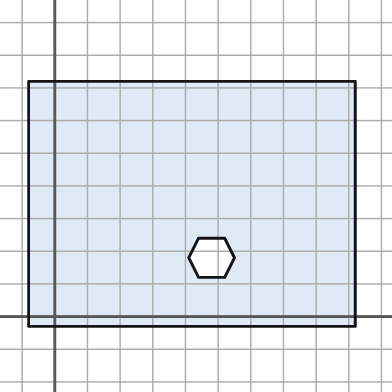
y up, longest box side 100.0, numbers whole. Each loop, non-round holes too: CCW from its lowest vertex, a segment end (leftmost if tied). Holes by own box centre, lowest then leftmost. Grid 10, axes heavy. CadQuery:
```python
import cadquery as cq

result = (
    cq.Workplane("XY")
    .moveTo(-8.0, -3.0)
    .lineTo(92.0, -3.0)
    .lineTo(92.0, 72.0)
    .lineTo(-8.0, 72.0)
    .close()
    .moveTo(44.0, 12.0)
    .lineTo(52.0, 12.0)
    .lineTo(55.0, 18.0)
    .lineTo(52.0, 24.0)
    .lineTo(44.0, 24.0)
    .lineTo(41.0, 18.0)
    .close()
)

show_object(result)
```